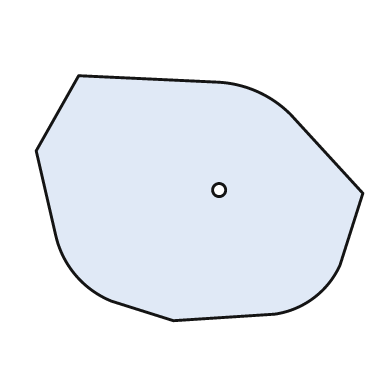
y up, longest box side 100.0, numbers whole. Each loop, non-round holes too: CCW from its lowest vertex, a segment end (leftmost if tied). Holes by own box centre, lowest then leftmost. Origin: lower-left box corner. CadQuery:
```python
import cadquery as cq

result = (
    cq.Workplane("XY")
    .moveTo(42.0, 0.0)
    .lineTo(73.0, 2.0)
    .threePointArc((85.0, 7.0), (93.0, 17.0))
    .lineTo(100.0, 39.0)
    .lineTo(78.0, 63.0)
    .threePointArc((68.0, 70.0), (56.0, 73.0))
    .lineTo(13.0, 75.0)
    .lineTo(0.0, 52.0)
    .lineTo(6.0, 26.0)
    .threePointArc((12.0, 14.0), (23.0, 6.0))
    .close()
    .moveTo(56.0, 40.0)
    .circle(2.0)
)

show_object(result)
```